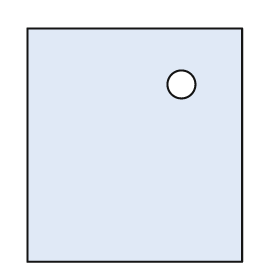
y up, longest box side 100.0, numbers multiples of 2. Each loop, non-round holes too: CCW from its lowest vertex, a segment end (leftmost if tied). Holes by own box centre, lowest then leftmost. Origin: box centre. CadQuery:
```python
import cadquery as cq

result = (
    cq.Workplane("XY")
    .moveTo(-46.0, -50.0)
    .lineTo(46.0, -50.0)
    .lineTo(46.0, 50.0)
    .lineTo(-46.0, 50.0)
    .close()
    .moveTo(20.0, 26.0)
    .circle(6.0)
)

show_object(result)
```